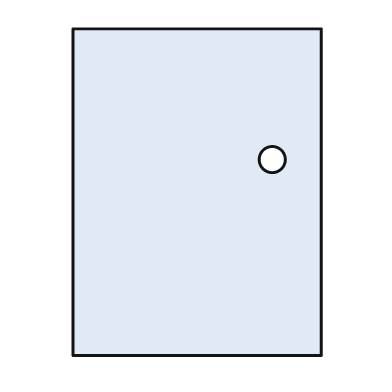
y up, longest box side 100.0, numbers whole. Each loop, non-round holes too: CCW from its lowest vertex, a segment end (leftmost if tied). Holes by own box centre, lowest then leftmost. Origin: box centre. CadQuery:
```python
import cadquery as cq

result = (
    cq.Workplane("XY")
    .moveTo(-38.0, -50.0)
    .lineTo(38.0, -50.0)
    .lineTo(38.0, 50.0)
    .lineTo(-38.0, 50.0)
    .close()
    .moveTo(23.0, 10.0)
    .circle(4.0)
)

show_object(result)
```